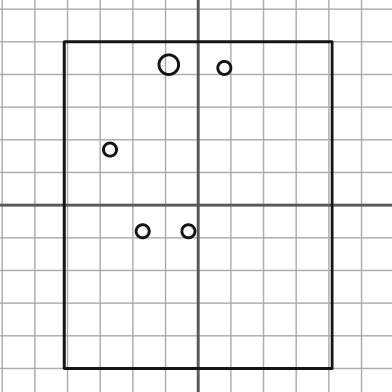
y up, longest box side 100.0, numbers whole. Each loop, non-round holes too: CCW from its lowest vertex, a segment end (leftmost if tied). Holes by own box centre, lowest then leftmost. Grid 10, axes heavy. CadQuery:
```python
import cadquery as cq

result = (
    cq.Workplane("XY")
    .moveTo(-41.0, -50.0)
    .lineTo(41.0, -50.0)
    .lineTo(41.0, 50.0)
    .lineTo(-41.0, 50.0)
    .close()
    .moveTo(-17.0, -8.0)
    .circle(2.0)
    .moveTo(-3.0, -8.0)
    .circle(2.0)
    .moveTo(-27.0, 17.0)
    .circle(2.0)
    .moveTo(8.0, 42.0)
    .circle(2.0)
    .moveTo(-9.0, 43.0)
    .circle(3.0)
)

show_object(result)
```